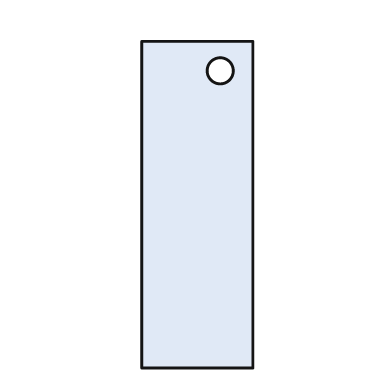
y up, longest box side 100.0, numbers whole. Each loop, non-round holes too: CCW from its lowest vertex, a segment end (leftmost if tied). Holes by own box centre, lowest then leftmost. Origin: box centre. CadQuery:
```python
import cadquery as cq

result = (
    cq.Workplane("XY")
    .moveTo(-17.0, -50.0)
    .lineTo(17.0, -50.0)
    .lineTo(17.0, 50.0)
    .lineTo(-17.0, 50.0)
    .close()
    .moveTo(7.0, 41.0)
    .circle(4.0)
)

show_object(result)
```